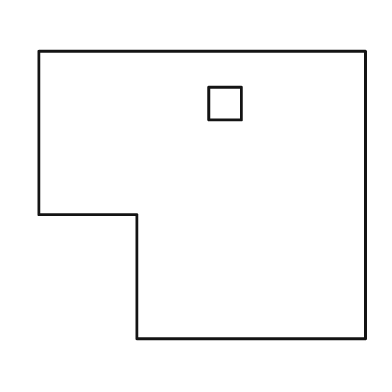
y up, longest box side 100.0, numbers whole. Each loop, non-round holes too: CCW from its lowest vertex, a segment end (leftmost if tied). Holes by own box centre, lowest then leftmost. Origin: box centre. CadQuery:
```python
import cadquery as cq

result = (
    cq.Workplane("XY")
    .moveTo(-20.0, -44.0)
    .lineTo(50.0, -44.0)
    .lineTo(50.0, 44.0)
    .lineTo(-50.0, 44.0)
    .lineTo(-50.0, -6.0)
    .lineTo(-20.0, -6.0)
    .close()
    .moveTo(2.0, 23.0)
    .lineTo(12.0, 23.0)
    .lineTo(12.0, 33.0)
    .lineTo(2.0, 33.0)
    .close()
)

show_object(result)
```